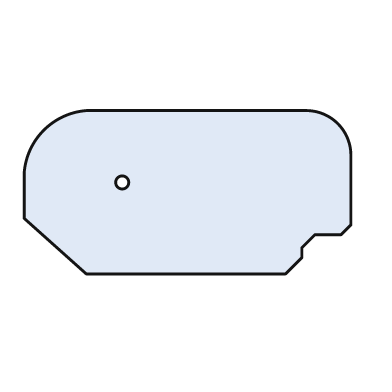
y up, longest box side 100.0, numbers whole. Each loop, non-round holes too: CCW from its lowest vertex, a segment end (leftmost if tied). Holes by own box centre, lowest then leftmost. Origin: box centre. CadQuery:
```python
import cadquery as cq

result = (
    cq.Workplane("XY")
    .moveTo(-31.0, -25.0)
    .lineTo(30.0, -25.0)
    .lineTo(35.0, -20.0)
    .lineTo(35.0, -17.0)
    .lineTo(39.0, -13.0)
    .lineTo(47.0, -13.0)
    .lineTo(50.0, -10.0)
    .lineTo(50.0, 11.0)
    .threePointArc((46.0, 21.0), (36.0, 25.0))
    .lineTo(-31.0, 25.0)
    .threePointArc((-44.0, 19.0), (-50.0, 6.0))
    .lineTo(-50.0, -8.0)
    .close()
    .moveTo(-20.0, 3.0)
    .circle(2.0)
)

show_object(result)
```